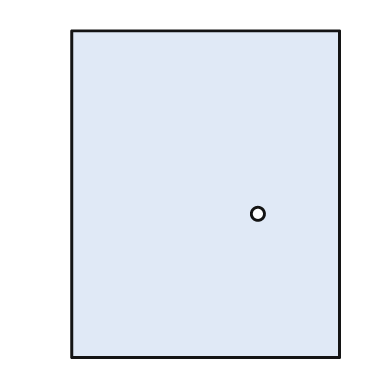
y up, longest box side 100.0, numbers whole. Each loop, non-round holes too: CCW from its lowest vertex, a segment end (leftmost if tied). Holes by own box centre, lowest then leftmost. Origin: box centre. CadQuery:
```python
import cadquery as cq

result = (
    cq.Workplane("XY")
    .moveTo(-41.0, -50.0)
    .lineTo(41.0, -50.0)
    .lineTo(41.0, 50.0)
    .lineTo(-41.0, 50.0)
    .close()
    .moveTo(16.0, -6.0)
    .circle(2.0)
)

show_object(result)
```